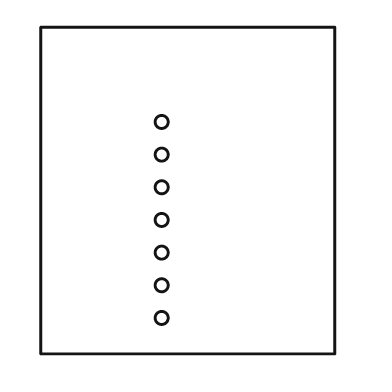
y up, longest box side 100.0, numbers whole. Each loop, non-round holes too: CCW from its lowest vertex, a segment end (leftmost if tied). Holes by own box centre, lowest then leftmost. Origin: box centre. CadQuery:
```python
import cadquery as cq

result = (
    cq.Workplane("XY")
    .moveTo(-45.0, -50.0)
    .lineTo(45.0, -50.0)
    .lineTo(45.0, 50.0)
    .lineTo(-45.0, 50.0)
    .close()
    .moveTo(-8.0, -39.0)
    .circle(2.0)
    .moveTo(-8.0, -29.0)
    .circle(2.0)
    .moveTo(-8.0, -19.0)
    .circle(2.0)
    .moveTo(-8.0, -9.0)
    .circle(2.0)
    .moveTo(-8.0, 1.0)
    .circle(2.0)
    .moveTo(-8.0, 11.0)
    .circle(2.0)
    .moveTo(-8.0, 21.0)
    .circle(2.0)
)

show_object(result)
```